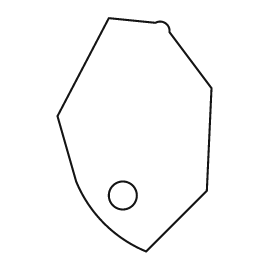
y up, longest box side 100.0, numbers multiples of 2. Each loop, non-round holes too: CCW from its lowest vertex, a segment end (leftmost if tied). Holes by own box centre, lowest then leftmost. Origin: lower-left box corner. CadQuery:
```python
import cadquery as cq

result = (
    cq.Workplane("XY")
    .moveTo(38.0, 0.0)
    .lineTo(64.0, 26.0)
    .lineTo(66.0, 70.0)
    .lineTo(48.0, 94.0)
    .threePointArc((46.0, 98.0), (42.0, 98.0))
    .lineTo(22.0, 100.0)
    .lineTo(0.0, 58.0)
    .lineTo(8.0, 30.0)
    .threePointArc((20.0, 12.0), (38.0, 0.0))
    .close()
    .moveTo(28.0, 24.0)
    .circle(6.0)
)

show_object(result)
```